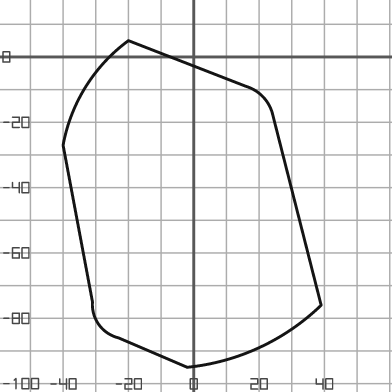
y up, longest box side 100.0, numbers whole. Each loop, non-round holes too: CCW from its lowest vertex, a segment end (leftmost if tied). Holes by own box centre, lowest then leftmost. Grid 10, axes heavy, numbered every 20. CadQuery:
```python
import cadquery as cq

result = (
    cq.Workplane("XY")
    .moveTo(-2.0, -95.0)
    .threePointArc((20.0, -89.0), (39.0, -76.0))
    .lineTo(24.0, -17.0)
    .threePointArc((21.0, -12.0), (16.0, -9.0))
    .lineTo(-20.0, 5.0)
    .threePointArc((-33.0, -9.0), (-40.0, -27.0))
    .lineTo(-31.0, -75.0)
    .threePointArc((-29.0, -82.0), (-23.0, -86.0))
    .close()
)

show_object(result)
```